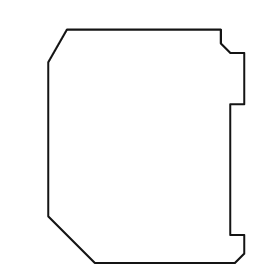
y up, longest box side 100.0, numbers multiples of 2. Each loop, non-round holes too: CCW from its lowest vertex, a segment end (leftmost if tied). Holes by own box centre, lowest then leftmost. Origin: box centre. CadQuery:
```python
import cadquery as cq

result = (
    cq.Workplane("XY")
    .moveTo(-22.0, -50.0)
    .lineTo(38.0, -50.0)
    .lineTo(42.0, -46.0)
    .lineTo(42.0, -38.0)
    .lineTo(36.0, -38.0)
    .lineTo(36.0, 18.0)
    .lineTo(42.0, 18.0)
    .lineTo(42.0, 40.0)
    .lineTo(36.0, 40.0)
    .lineTo(32.0, 44.0)
    .lineTo(32.0, 50.0)
    .lineTo(-34.0, 50.0)
    .lineTo(-42.0, 36.0)
    .lineTo(-42.0, -30.0)
    .close()
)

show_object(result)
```